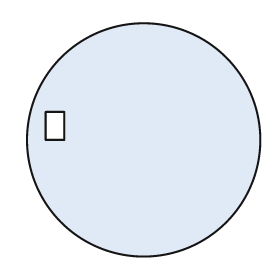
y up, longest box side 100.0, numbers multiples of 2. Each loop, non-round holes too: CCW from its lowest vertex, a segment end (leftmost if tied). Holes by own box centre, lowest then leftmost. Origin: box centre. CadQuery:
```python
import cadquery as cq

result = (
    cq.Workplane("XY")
    .moveTo(0.0, 0.0)
    .circle(50.0)
    .moveTo(-42.0, 0.0)
    .lineTo(-34.0, 0.0)
    .lineTo(-34.0, 12.0)
    .lineTo(-42.0, 12.0)
    .close()
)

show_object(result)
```